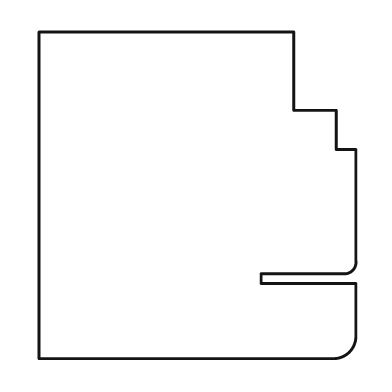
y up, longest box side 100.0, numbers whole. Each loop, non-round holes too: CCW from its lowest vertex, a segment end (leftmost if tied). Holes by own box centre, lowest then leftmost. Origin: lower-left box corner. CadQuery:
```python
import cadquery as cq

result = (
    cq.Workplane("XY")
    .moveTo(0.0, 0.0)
    .lineTo(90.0, 0.0)
    .threePointArc((95.0, 2.0), (97.0, 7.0))
    .lineTo(97.0, 23.0)
    .lineTo(68.0, 23.0)
    .lineTo(68.0, 26.0)
    .lineTo(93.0, 26.0)
    .threePointArc((96.0, 27.0), (97.0, 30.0))
    .lineTo(97.0, 64.0)
    .lineTo(91.0, 64.0)
    .lineTo(91.0, 76.0)
    .lineTo(78.0, 76.0)
    .lineTo(78.0, 100.0)
    .lineTo(0.0, 100.0)
    .close()
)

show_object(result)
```